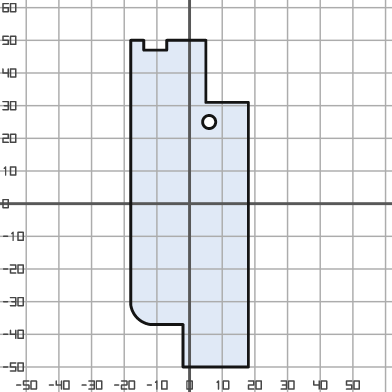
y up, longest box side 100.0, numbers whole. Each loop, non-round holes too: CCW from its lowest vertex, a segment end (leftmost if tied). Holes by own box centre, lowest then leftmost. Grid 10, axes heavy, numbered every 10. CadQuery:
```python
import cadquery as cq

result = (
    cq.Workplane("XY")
    .moveTo(-2.0, -50.0)
    .lineTo(18.0, -50.0)
    .lineTo(18.0, 31.0)
    .lineTo(5.0, 31.0)
    .lineTo(5.0, 50.0)
    .lineTo(-7.0, 50.0)
    .lineTo(-7.0, 47.0)
    .lineTo(-14.0, 47.0)
    .lineTo(-14.0, 50.0)
    .lineTo(-18.0, 50.0)
    .lineTo(-18.0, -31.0)
    .threePointArc((-16.0, -35.0), (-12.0, -37.0))
    .lineTo(-2.0, -37.0)
    .close()
    .moveTo(6.0, 25.0)
    .circle(2.0)
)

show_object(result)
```